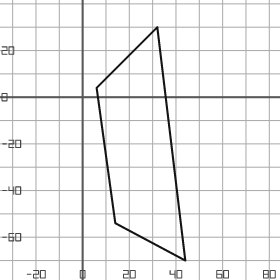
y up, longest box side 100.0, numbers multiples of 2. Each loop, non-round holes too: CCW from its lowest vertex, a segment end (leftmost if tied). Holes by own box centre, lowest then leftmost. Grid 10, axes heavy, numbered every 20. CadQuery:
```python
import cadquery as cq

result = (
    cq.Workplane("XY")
    .moveTo(44.0, -70.0)
    .lineTo(32.0, 30.0)
    .lineTo(6.0, 4.0)
    .lineTo(14.0, -54.0)
    .close()
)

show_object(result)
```